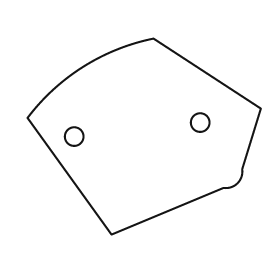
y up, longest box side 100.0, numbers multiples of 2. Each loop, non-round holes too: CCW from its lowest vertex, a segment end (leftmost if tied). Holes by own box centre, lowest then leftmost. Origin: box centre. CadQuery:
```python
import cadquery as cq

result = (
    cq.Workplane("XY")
    .moveTo(-14.0, -42.0)
    .lineTo(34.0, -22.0)
    .threePointArc((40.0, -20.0), (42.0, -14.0))
    .lineTo(50.0, 12.0)
    .lineTo(4.0, 42.0)
    .threePointArc((-26.0, 30.0), (-50.0, 8.0))
    .close()
    .moveTo(-30.0, 0.0)
    .circle(4.0)
    .moveTo(24.0, 6.0)
    .circle(4.0)
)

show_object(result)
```